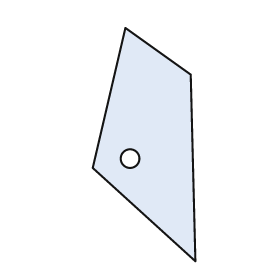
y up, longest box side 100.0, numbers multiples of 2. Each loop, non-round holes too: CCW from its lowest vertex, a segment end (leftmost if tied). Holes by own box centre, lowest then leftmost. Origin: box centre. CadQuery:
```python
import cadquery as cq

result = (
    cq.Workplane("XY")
    .moveTo(22.0, -50.0)
    .lineTo(20.0, 30.0)
    .lineTo(-8.0, 50.0)
    .lineTo(-22.0, -10.0)
    .close()
    .moveTo(-6.0, -6.0)
    .circle(4.0)
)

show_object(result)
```